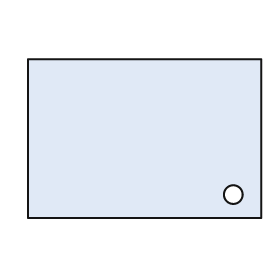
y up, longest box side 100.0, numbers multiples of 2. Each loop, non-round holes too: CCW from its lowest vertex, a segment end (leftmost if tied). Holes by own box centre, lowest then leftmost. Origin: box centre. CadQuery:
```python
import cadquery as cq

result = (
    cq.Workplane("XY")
    .moveTo(-50.0, -34.0)
    .lineTo(50.0, -34.0)
    .lineTo(50.0, 34.0)
    .lineTo(-50.0, 34.0)
    .close()
    .moveTo(38.0, -24.0)
    .circle(4.0)
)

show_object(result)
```